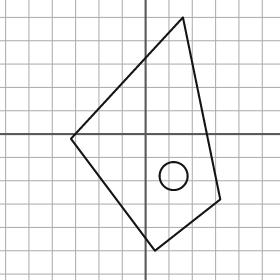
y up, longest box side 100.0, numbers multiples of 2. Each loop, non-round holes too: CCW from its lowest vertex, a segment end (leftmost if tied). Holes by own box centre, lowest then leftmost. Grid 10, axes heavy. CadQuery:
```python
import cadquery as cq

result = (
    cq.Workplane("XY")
    .moveTo(4.0, -50.0)
    .lineTo(32.0, -28.0)
    .lineTo(16.0, 50.0)
    .lineTo(-32.0, -2.0)
    .close()
    .moveTo(12.0, -18.0)
    .circle(6.0)
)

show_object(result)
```